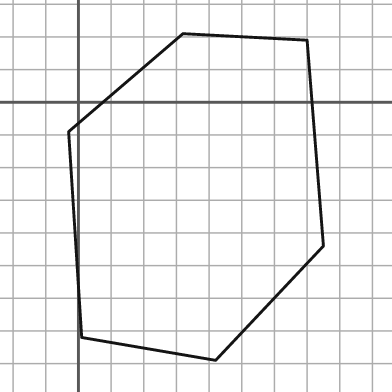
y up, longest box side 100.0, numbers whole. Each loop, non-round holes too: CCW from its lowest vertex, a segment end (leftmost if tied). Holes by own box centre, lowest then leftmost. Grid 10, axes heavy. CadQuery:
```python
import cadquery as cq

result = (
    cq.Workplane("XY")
    .moveTo(42.0, -79.0)
    .lineTo(75.0, -44.0)
    .lineTo(70.0, 19.0)
    .lineTo(32.0, 21.0)
    .lineTo(-3.0, -9.0)
    .lineTo(1.0, -72.0)
    .close()
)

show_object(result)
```